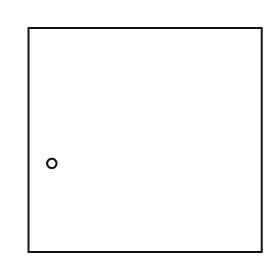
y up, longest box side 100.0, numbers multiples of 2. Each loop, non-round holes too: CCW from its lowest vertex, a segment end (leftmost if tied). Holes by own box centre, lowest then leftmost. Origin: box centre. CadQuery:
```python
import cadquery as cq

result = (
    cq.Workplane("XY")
    .moveTo(-50.0, -48.0)
    .lineTo(50.0, -48.0)
    .lineTo(50.0, 48.0)
    .lineTo(-50.0, 48.0)
    .close()
    .moveTo(-40.0, -10.0)
    .circle(2.0)
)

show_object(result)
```